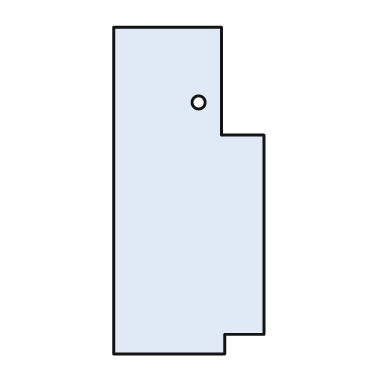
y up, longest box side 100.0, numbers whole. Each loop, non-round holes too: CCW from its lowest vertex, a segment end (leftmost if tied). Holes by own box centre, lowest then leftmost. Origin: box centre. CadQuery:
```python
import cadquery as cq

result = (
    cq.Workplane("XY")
    .moveTo(-23.0, -50.0)
    .lineTo(11.0, -50.0)
    .lineTo(11.0, -44.0)
    .lineTo(23.0, -44.0)
    .lineTo(23.0, 17.0)
    .lineTo(10.0, 17.0)
    .lineTo(10.0, 50.0)
    .lineTo(-23.0, 50.0)
    .close()
    .moveTo(3.0, 27.0)
    .circle(2.0)
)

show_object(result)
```